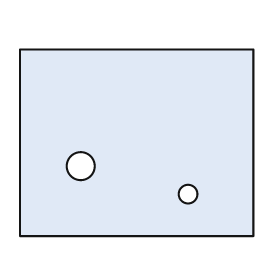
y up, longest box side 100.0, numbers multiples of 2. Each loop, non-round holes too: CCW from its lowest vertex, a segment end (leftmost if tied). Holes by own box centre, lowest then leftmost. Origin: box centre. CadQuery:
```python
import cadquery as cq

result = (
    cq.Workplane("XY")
    .moveTo(-50.0, -40.0)
    .lineTo(50.0, -40.0)
    .lineTo(50.0, 40.0)
    .lineTo(-50.0, 40.0)
    .close()
    .moveTo(22.0, -22.0)
    .circle(4.0)
    .moveTo(-24.0, -10.0)
    .circle(6.0)
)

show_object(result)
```